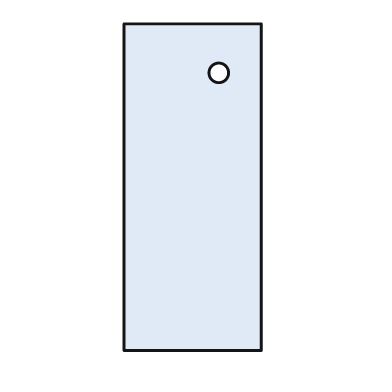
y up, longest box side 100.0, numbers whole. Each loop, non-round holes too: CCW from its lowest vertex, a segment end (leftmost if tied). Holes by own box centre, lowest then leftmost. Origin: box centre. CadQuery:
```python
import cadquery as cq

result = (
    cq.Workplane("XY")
    .moveTo(-21.0, -50.0)
    .lineTo(21.0, -50.0)
    .lineTo(21.0, 50.0)
    .lineTo(-21.0, 50.0)
    .close()
    .moveTo(8.0, 35.0)
    .circle(3.0)
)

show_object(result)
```